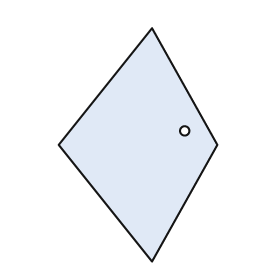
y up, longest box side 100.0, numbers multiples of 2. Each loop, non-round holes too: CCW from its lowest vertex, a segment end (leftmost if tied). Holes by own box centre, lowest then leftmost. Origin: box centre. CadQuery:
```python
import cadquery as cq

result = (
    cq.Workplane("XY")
    .moveTo(6.0, -50.0)
    .lineTo(34.0, 0.0)
    .lineTo(6.0, 50.0)
    .lineTo(-34.0, 0.0)
    .close()
    .moveTo(20.0, 6.0)
    .circle(2.0)
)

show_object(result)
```